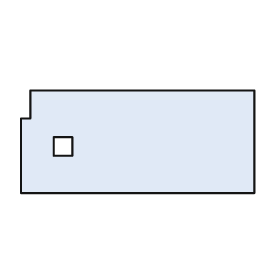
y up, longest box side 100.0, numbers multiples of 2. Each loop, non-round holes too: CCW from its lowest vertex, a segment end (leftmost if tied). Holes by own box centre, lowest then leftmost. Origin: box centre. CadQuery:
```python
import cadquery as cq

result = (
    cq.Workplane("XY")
    .moveTo(-50.0, -22.0)
    .lineTo(50.0, -22.0)
    .lineTo(50.0, 22.0)
    .lineTo(-46.0, 22.0)
    .lineTo(-46.0, 10.0)
    .lineTo(-50.0, 10.0)
    .close()
    .moveTo(-36.0, -6.0)
    .lineTo(-28.0, -6.0)
    .lineTo(-28.0, 2.0)
    .lineTo(-36.0, 2.0)
    .close()
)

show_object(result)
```